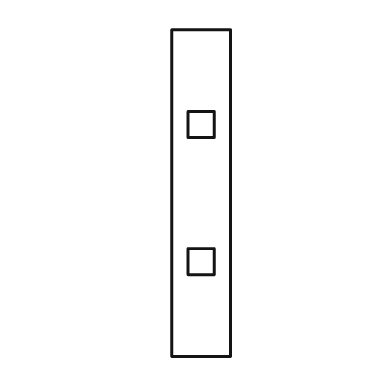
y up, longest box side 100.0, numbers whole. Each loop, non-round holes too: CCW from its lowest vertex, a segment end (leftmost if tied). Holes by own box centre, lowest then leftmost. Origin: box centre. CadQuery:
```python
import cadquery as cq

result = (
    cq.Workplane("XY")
    .moveTo(-9.0, -50.0)
    .lineTo(9.0, -50.0)
    .lineTo(9.0, 50.0)
    .lineTo(-9.0, 50.0)
    .close()
    .moveTo(-4.0, -25.0)
    .lineTo(4.0, -25.0)
    .lineTo(4.0, -17.0)
    .lineTo(-4.0, -17.0)
    .close()
    .moveTo(-4.0, 17.0)
    .lineTo(4.0, 17.0)
    .lineTo(4.0, 25.0)
    .lineTo(-4.0, 25.0)
    .close()
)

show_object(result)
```